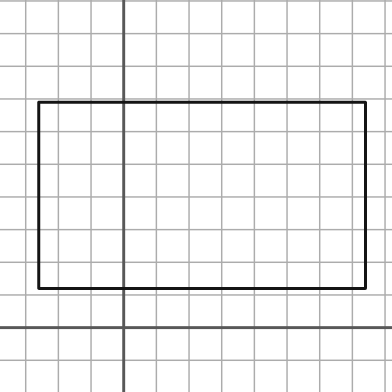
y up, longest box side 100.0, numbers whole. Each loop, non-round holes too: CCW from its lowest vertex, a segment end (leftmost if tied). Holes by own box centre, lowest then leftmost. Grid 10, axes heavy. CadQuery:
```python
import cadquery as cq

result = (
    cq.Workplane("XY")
    .moveTo(-26.0, 12.0)
    .lineTo(74.0, 12.0)
    .lineTo(74.0, 69.0)
    .lineTo(-26.0, 69.0)
    .close()
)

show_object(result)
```